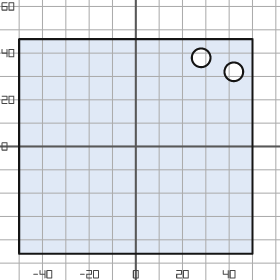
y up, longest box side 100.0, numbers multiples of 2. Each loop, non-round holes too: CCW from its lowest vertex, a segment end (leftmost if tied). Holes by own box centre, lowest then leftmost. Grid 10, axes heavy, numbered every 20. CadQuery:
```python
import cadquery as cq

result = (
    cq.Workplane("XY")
    .moveTo(-50.0, -46.0)
    .lineTo(50.0, -46.0)
    .lineTo(50.0, 46.0)
    .lineTo(-50.0, 46.0)
    .close()
    .moveTo(42.0, 32.0)
    .circle(4.0)
    .moveTo(28.0, 38.0)
    .circle(4.0)
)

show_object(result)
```